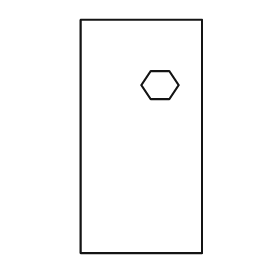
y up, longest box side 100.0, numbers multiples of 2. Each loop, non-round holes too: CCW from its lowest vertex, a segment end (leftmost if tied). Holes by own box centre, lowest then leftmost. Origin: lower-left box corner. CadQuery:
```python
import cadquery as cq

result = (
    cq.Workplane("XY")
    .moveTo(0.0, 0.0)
    .lineTo(52.0, 0.0)
    .lineTo(52.0, 100.0)
    .lineTo(0.0, 100.0)
    .close()
    .moveTo(30.0, 66.0)
    .lineTo(38.0, 66.0)
    .lineTo(42.0, 72.0)
    .lineTo(38.0, 78.0)
    .lineTo(30.0, 78.0)
    .lineTo(26.0, 72.0)
    .close()
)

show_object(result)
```